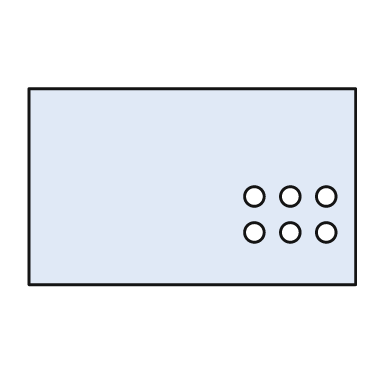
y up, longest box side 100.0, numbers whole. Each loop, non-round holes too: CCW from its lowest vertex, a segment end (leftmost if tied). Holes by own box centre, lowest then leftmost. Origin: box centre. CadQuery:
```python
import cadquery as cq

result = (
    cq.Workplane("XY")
    .moveTo(-50.0, -30.0)
    .lineTo(50.0, -30.0)
    .lineTo(50.0, 30.0)
    .lineTo(-50.0, 30.0)
    .close()
    .moveTo(19.0, -14.0)
    .circle(3.0)
    .moveTo(30.0, -14.0)
    .circle(3.0)
    .moveTo(41.0, -14.0)
    .circle(3.0)
    .moveTo(19.0, -3.0)
    .circle(3.0)
    .moveTo(30.0, -3.0)
    .circle(3.0)
    .moveTo(41.0, -3.0)
    .circle(3.0)
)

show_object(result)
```